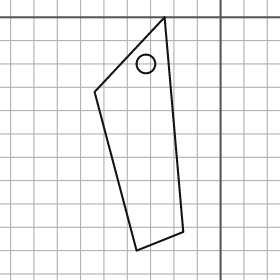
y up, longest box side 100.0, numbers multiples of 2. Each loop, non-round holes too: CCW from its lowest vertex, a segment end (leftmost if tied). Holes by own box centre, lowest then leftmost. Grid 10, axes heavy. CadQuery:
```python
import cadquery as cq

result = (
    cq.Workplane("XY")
    .moveTo(-36.0, -100.0)
    .lineTo(-16.0, -92.0)
    .lineTo(-24.0, 0.0)
    .lineTo(-54.0, -32.0)
    .close()
    .moveTo(-32.0, -20.0)
    .circle(4.0)
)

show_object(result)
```